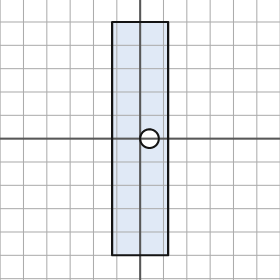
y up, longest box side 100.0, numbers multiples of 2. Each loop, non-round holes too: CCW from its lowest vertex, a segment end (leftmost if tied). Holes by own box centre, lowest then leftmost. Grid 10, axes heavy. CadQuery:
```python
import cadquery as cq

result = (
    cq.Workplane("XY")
    .moveTo(-12.0, -50.0)
    .lineTo(12.0, -50.0)
    .lineTo(12.0, 50.0)
    .lineTo(-12.0, 50.0)
    .close()
    .moveTo(4.0, 0.0)
    .circle(4.0)
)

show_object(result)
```